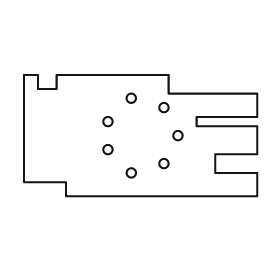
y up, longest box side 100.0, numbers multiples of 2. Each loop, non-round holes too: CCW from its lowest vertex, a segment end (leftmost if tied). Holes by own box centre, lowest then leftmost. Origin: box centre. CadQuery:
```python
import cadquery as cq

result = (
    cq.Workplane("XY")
    .moveTo(-32.0, -26.0)
    .lineTo(50.0, -26.0)
    .lineTo(50.0, -16.0)
    .lineTo(32.0, -16.0)
    .lineTo(32.0, -8.0)
    .lineTo(50.0, -8.0)
    .lineTo(50.0, 4.0)
    .lineTo(24.0, 4.0)
    .lineTo(24.0, 8.0)
    .lineTo(50.0, 8.0)
    .lineTo(50.0, 18.0)
    .lineTo(12.0, 18.0)
    .lineTo(12.0, 26.0)
    .lineTo(-36.0, 26.0)
    .lineTo(-36.0, 20.0)
    .lineTo(-44.0, 20.0)
    .lineTo(-44.0, 26.0)
    .lineTo(-50.0, 26.0)
    .lineTo(-50.0, -20.0)
    .lineTo(-32.0, -20.0)
    .close()
    .moveTo(-4.0, -16.0)
    .circle(2.0)
    .moveTo(10.0, -12.0)
    .circle(2.0)
    .moveTo(-14.0, -6.0)
    .circle(2.0)
    .moveTo(16.0, 0.0)
    .circle(2.0)
    .moveTo(-14.0, 6.0)
    .circle(2.0)
    .moveTo(10.0, 12.0)
    .circle(2.0)
    .moveTo(-4.0, 16.0)
    .circle(2.0)
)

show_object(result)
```